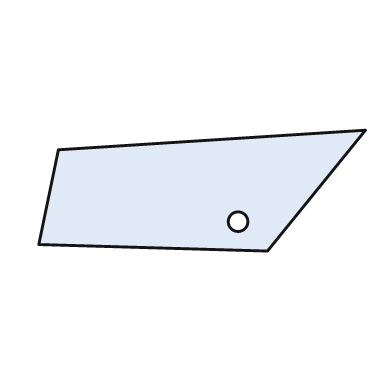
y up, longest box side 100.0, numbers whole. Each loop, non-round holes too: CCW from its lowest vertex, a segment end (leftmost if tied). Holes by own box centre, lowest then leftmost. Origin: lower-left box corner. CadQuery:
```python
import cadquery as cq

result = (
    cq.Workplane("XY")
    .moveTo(70.0, 0.0)
    .lineTo(100.0, 37.0)
    .lineTo(6.0, 31.0)
    .lineTo(0.0, 2.0)
    .close()
    .moveTo(61.0, 9.0)
    .circle(3.0)
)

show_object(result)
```